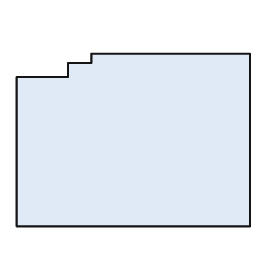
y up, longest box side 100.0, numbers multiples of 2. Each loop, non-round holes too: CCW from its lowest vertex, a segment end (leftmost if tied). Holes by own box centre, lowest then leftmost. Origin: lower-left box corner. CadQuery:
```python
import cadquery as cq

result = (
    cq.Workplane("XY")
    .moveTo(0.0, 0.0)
    .lineTo(100.0, 0.0)
    .lineTo(100.0, 74.0)
    .lineTo(32.0, 74.0)
    .lineTo(32.0, 70.0)
    .lineTo(22.0, 70.0)
    .lineTo(22.0, 64.0)
    .lineTo(0.0, 64.0)
    .close()
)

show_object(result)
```